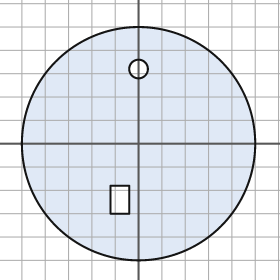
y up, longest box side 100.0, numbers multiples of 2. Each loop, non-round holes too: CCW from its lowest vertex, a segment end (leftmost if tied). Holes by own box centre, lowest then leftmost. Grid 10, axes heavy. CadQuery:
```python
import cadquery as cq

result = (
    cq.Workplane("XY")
    .moveTo(0.0, 0.0)
    .circle(50.0)
    .moveTo(-12.0, -30.0)
    .lineTo(-4.0, -30.0)
    .lineTo(-4.0, -18.0)
    .lineTo(-12.0, -18.0)
    .close()
    .moveTo(0.0, 32.0)
    .circle(4.0)
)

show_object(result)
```